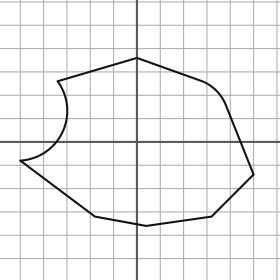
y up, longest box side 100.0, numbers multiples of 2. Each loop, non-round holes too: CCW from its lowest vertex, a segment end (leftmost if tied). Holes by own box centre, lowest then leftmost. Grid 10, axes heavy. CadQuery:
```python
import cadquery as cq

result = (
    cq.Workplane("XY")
    .moveTo(4.0, -36.0)
    .lineTo(32.0, -32.0)
    .lineTo(50.0, -14.0)
    .lineTo(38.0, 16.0)
    .threePointArc((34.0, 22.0), (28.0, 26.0))
    .lineTo(0.0, 36.0)
    .lineTo(-34.0, 26.0)
    .threePointArc((-32.0, 4.0), (-50.0, -8.0))
    .lineTo(-18.0, -32.0)
    .close()
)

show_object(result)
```